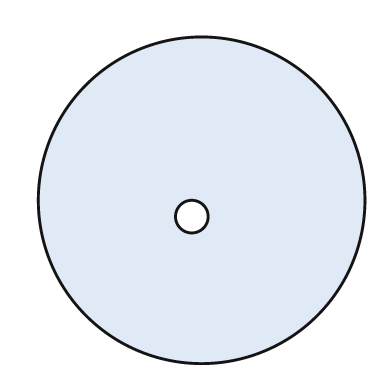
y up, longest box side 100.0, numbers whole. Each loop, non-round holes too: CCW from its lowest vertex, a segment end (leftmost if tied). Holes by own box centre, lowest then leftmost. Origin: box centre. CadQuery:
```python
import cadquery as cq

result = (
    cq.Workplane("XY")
    .moveTo(0.0, 0.0)
    .circle(50.0)
    .moveTo(-3.0, -5.0)
    .circle(5.0)
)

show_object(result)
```